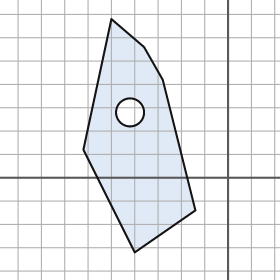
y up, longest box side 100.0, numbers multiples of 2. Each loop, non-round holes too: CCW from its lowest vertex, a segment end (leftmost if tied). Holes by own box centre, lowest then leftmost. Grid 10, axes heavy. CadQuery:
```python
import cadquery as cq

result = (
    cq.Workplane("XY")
    .moveTo(-40.0, -32.0)
    .lineTo(-14.0, -14.0)
    .lineTo(-28.0, 42.0)
    .lineTo(-36.0, 56.0)
    .lineTo(-50.0, 68.0)
    .lineTo(-62.0, 12.0)
    .close()
    .moveTo(-42.0, 28.0)
    .circle(6.0)
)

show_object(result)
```